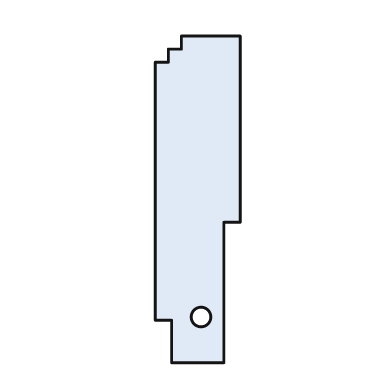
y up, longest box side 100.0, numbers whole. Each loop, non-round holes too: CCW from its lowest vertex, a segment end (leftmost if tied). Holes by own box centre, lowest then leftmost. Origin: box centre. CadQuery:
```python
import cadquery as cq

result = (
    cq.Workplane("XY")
    .moveTo(-8.0, -50.0)
    .lineTo(8.0, -50.0)
    .lineTo(8.0, -7.0)
    .lineTo(13.0, -7.0)
    .lineTo(13.0, 50.0)
    .lineTo(-5.0, 50.0)
    .lineTo(-5.0, 46.0)
    .lineTo(-9.0, 46.0)
    .lineTo(-9.0, 42.0)
    .lineTo(-13.0, 42.0)
    .lineTo(-13.0, -37.0)
    .lineTo(-8.0, -37.0)
    .close()
    .moveTo(1.0, -36.0)
    .circle(3.0)
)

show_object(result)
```